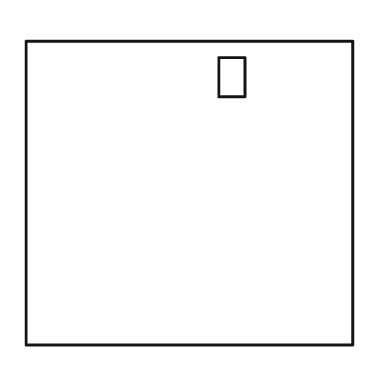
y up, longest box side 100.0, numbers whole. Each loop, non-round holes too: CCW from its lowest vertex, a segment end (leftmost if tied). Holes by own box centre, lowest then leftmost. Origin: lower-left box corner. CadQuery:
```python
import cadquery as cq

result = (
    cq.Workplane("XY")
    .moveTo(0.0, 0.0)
    .lineTo(100.0, 0.0)
    .lineTo(100.0, 93.0)
    .lineTo(0.0, 93.0)
    .close()
    .moveTo(59.0, 76.0)
    .lineTo(67.0, 76.0)
    .lineTo(67.0, 88.0)
    .lineTo(59.0, 88.0)
    .close()
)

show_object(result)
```